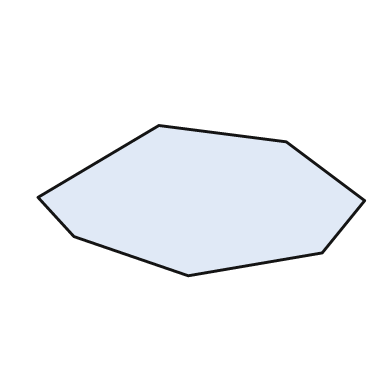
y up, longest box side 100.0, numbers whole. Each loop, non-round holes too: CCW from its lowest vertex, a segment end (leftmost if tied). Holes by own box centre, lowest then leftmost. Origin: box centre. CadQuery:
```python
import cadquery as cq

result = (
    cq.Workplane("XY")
    .moveTo(-4.0, -23.0)
    .lineTo(37.0, -16.0)
    .lineTo(50.0, 0.0)
    .lineTo(26.0, 18.0)
    .lineTo(-13.0, 23.0)
    .lineTo(-50.0, 1.0)
    .lineTo(-39.0, -11.0)
    .close()
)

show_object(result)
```